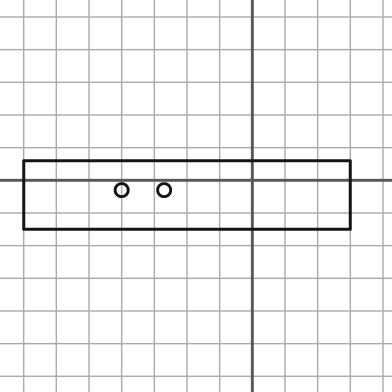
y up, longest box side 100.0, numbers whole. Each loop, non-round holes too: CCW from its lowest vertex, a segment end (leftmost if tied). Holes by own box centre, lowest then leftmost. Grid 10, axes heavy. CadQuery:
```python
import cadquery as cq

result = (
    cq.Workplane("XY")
    .moveTo(-70.0, -15.0)
    .lineTo(30.0, -15.0)
    .lineTo(30.0, 6.0)
    .lineTo(-70.0, 6.0)
    .close()
    .moveTo(-40.0, -3.0)
    .circle(2.0)
    .moveTo(-27.0, -3.0)
    .circle(2.0)
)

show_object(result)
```